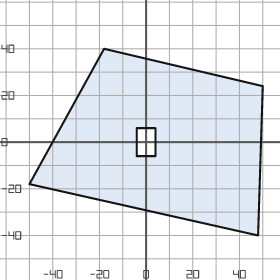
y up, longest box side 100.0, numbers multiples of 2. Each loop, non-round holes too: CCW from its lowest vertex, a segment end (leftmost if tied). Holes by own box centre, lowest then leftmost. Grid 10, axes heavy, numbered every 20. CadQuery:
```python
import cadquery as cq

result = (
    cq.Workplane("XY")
    .moveTo(48.0, -40.0)
    .lineTo(50.0, 24.0)
    .lineTo(-18.0, 40.0)
    .lineTo(-50.0, -18.0)
    .close()
    .moveTo(-4.0, -6.0)
    .lineTo(4.0, -6.0)
    .lineTo(4.0, 6.0)
    .lineTo(-4.0, 6.0)
    .close()
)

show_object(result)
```